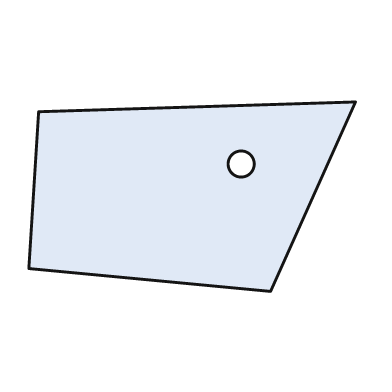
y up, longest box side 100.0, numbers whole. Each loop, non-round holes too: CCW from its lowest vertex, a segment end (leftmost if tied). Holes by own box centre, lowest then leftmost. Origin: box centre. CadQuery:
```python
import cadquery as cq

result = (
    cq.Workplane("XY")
    .moveTo(24.0, -29.0)
    .lineTo(50.0, 29.0)
    .lineTo(-47.0, 26.0)
    .lineTo(-50.0, -22.0)
    .close()
    .moveTo(15.0, 10.0)
    .circle(4.0)
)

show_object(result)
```